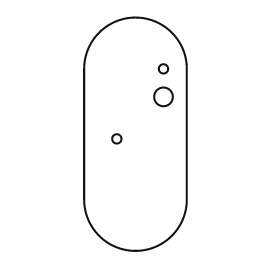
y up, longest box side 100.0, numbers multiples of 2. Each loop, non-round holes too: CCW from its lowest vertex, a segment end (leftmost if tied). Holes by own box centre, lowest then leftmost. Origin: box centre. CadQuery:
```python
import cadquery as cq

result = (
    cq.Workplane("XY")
    .moveTo(-22.0, -28.0)
    .threePointArc((0.0, -50.0), (22.0, -28.0))
    .lineTo(22.0, 28.0)
    .threePointArc((0.0, 50.0), (-22.0, 28.0))
    .close()
    .moveTo(-8.0, -2.0)
    .circle(2.0)
    .moveTo(12.0, 16.0)
    .circle(4.0)
    .moveTo(12.0, 28.0)
    .circle(2.0)
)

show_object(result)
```